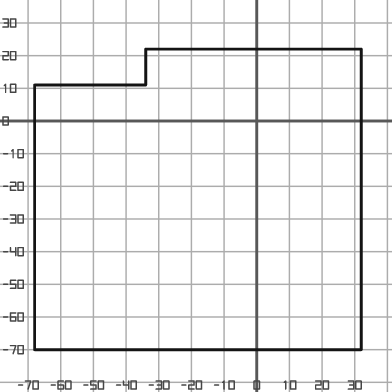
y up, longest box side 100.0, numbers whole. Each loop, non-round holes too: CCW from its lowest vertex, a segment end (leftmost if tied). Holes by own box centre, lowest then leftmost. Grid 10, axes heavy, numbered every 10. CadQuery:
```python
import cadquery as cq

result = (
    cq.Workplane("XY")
    .moveTo(-68.0, -70.0)
    .lineTo(32.0, -70.0)
    .lineTo(32.0, 22.0)
    .lineTo(-34.0, 22.0)
    .lineTo(-34.0, 11.0)
    .lineTo(-68.0, 11.0)
    .close()
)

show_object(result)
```